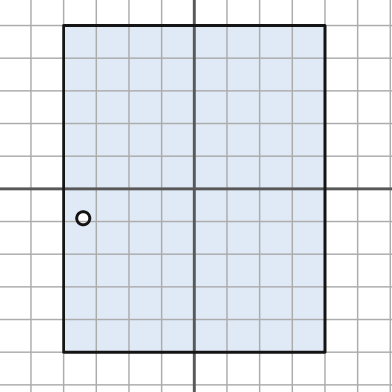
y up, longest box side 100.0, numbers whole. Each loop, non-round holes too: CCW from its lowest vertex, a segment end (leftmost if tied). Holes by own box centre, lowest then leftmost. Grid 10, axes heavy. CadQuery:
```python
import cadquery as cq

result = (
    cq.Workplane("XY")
    .moveTo(-40.0, -50.0)
    .lineTo(40.0, -50.0)
    .lineTo(40.0, 50.0)
    .lineTo(-40.0, 50.0)
    .close()
    .moveTo(-34.0, -9.0)
    .circle(2.0)
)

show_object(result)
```